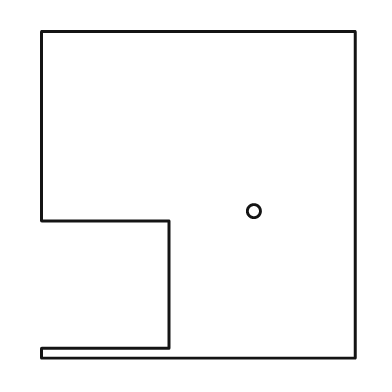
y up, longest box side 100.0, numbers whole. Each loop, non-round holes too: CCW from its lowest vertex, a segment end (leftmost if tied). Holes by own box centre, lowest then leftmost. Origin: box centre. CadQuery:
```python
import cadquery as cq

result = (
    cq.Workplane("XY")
    .moveTo(-48.0, -50.0)
    .lineTo(48.0, -50.0)
    .lineTo(48.0, 50.0)
    .lineTo(-48.0, 50.0)
    .lineTo(-48.0, -8.0)
    .lineTo(-9.0, -8.0)
    .lineTo(-9.0, -47.0)
    .lineTo(-48.0, -47.0)
    .close()
    .moveTo(17.0, -5.0)
    .circle(2.0)
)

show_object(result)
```